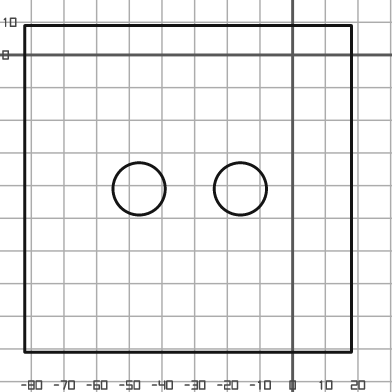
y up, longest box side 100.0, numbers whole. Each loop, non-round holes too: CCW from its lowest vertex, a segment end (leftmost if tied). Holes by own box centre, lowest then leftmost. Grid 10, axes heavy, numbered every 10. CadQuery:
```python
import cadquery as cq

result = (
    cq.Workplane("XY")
    .moveTo(-82.0, -91.0)
    .lineTo(18.0, -91.0)
    .lineTo(18.0, 9.0)
    .lineTo(-82.0, 9.0)
    .close()
    .moveTo(-47.0, -41.0)
    .circle(8.0)
    .moveTo(-16.0, -41.0)
    .circle(8.0)
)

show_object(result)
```